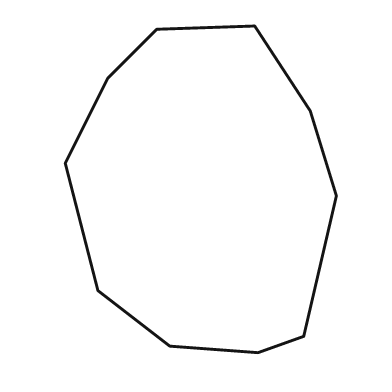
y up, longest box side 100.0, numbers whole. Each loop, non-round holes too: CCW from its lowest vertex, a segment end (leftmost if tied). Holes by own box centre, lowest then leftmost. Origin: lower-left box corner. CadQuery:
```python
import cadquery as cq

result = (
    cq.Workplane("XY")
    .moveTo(59.0, 0.0)
    .lineTo(73.0, 5.0)
    .lineTo(83.0, 48.0)
    .lineTo(75.0, 74.0)
    .lineTo(58.0, 100.0)
    .lineTo(28.0, 99.0)
    .lineTo(13.0, 84.0)
    .lineTo(0.0, 58.0)
    .lineTo(10.0, 19.0)
    .lineTo(32.0, 2.0)
    .close()
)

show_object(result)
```